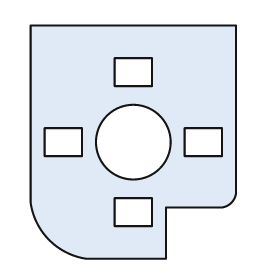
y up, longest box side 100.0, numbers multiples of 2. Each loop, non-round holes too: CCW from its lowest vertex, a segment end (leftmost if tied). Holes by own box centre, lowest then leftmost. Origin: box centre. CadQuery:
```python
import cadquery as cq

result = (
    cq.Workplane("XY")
    .moveTo(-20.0, -50.0)
    .lineTo(14.0, -50.0)
    .lineTo(14.0, -28.0)
    .lineTo(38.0, -28.0)
    .threePointArc((42.0, -26.0), (44.0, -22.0))
    .lineTo(44.0, 50.0)
    .lineTo(-44.0, 50.0)
    .lineTo(-44.0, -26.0)
    .threePointArc((-36.0, -42.0), (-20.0, -50.0))
    .close()
    .moveTo(-8.0, -36.0)
    .lineTo(8.0, -36.0)
    .lineTo(8.0, -24.0)
    .lineTo(-8.0, -24.0)
    .close()
    .moveTo(-38.0, -6.0)
    .lineTo(-22.0, -6.0)
    .lineTo(-22.0, 6.0)
    .lineTo(-38.0, 6.0)
    .close()
    .moveTo(0.0, 0.0)
    .circle(16.0)
    .moveTo(22.0, -6.0)
    .lineTo(38.0, -6.0)
    .lineTo(38.0, 6.0)
    .lineTo(22.0, 6.0)
    .close()
    .moveTo(-8.0, 24.0)
    .lineTo(8.0, 24.0)
    .lineTo(8.0, 36.0)
    .lineTo(-8.0, 36.0)
    .close()
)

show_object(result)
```